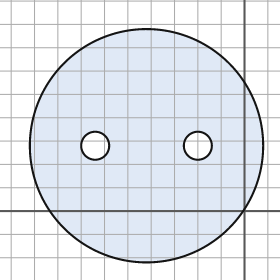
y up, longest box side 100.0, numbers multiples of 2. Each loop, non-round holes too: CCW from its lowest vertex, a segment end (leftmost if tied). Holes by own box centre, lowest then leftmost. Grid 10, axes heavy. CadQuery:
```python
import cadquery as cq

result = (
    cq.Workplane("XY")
    .moveTo(-42.0, 28.0)
    .circle(50.0)
    .moveTo(-64.0, 28.0)
    .circle(6.0)
    .moveTo(-20.0, 28.0)
    .circle(6.0)
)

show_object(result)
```